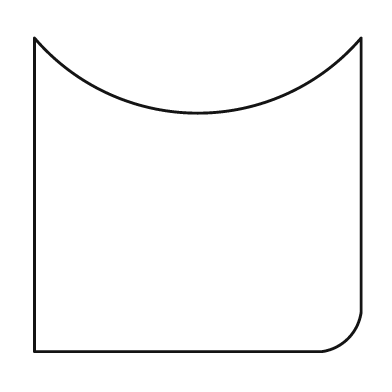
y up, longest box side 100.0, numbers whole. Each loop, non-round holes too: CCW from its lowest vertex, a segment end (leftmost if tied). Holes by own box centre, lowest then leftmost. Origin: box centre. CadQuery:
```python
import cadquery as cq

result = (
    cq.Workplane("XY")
    .moveTo(-50.0, -48.0)
    .lineTo(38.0, -48.0)
    .threePointArc((46.0, -44.0), (50.0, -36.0))
    .lineTo(50.0, 48.0)
    .threePointArc((0.0, 25.0), (-50.0, 48.0))
    .close()
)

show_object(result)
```